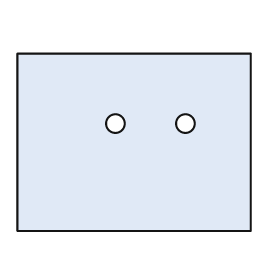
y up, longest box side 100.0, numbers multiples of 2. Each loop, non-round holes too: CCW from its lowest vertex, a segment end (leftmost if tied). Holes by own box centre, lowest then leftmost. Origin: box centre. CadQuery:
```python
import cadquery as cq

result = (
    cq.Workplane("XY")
    .moveTo(-50.0, -38.0)
    .lineTo(50.0, -38.0)
    .lineTo(50.0, 38.0)
    .lineTo(-50.0, 38.0)
    .close()
    .moveTo(-8.0, 8.0)
    .circle(4.0)
    .moveTo(22.0, 8.0)
    .circle(4.0)
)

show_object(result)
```